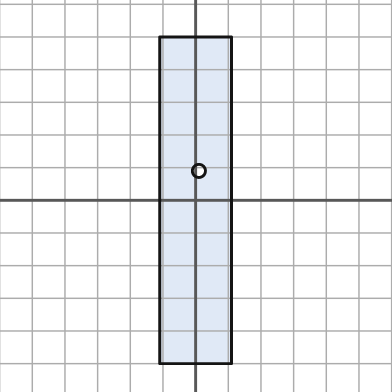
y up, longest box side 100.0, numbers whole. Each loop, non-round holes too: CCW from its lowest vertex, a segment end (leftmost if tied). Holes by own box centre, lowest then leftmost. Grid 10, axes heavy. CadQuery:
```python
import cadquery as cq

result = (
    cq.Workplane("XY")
    .moveTo(-11.0, -50.0)
    .lineTo(11.0, -50.0)
    .lineTo(11.0, 50.0)
    .lineTo(-11.0, 50.0)
    .close()
    .moveTo(1.0, 9.0)
    .circle(2.0)
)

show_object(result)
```